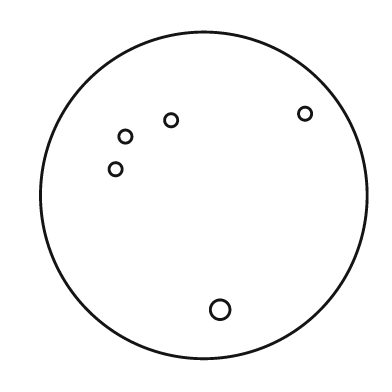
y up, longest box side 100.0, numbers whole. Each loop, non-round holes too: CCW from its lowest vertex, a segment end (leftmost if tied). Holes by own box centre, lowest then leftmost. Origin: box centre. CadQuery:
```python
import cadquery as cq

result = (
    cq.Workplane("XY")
    .moveTo(0.0, 0.0)
    .circle(50.0)
    .moveTo(5.0, -35.0)
    .circle(3.0)
    .moveTo(-27.0, 8.0)
    .circle(2.0)
    .moveTo(-24.0, 18.0)
    .circle(2.0)
    .moveTo(-10.0, 23.0)
    .circle(2.0)
    .moveTo(31.0, 25.0)
    .circle(2.0)
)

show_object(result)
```